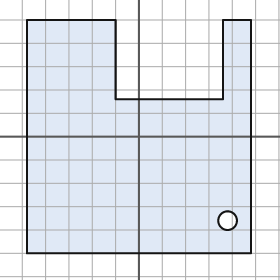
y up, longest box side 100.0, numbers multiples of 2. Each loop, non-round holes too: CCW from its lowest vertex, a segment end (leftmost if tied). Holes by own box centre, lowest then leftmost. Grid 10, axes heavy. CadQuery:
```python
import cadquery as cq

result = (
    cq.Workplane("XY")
    .moveTo(-48.0, -50.0)
    .lineTo(48.0, -50.0)
    .lineTo(48.0, 50.0)
    .lineTo(36.0, 50.0)
    .lineTo(36.0, 16.0)
    .lineTo(-10.0, 16.0)
    .lineTo(-10.0, 50.0)
    .lineTo(-48.0, 50.0)
    .close()
    .moveTo(38.0, -36.0)
    .circle(4.0)
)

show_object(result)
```